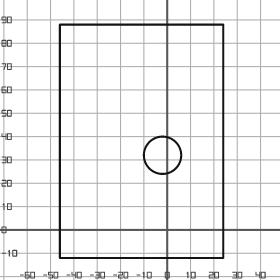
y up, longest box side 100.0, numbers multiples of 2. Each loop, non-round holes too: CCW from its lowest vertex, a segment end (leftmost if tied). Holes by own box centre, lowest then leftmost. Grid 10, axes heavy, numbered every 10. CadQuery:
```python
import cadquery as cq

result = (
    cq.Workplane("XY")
    .moveTo(-46.0, -12.0)
    .lineTo(24.0, -12.0)
    .lineTo(24.0, 88.0)
    .lineTo(-46.0, 88.0)
    .close()
    .moveTo(-2.0, 32.0)
    .circle(8.0)
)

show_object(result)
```